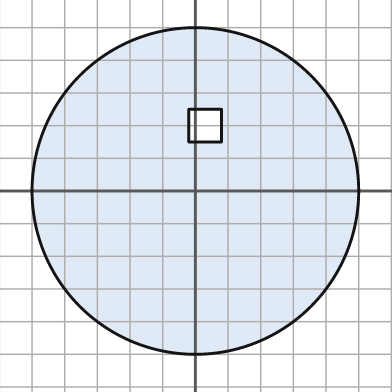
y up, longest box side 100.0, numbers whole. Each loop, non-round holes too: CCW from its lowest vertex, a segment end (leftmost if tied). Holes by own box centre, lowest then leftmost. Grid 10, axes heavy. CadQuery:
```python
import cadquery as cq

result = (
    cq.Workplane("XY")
    .moveTo(0.0, 0.0)
    .circle(50.0)
    .moveTo(-2.0, 15.0)
    .lineTo(8.0, 15.0)
    .lineTo(8.0, 25.0)
    .lineTo(-2.0, 25.0)
    .close()
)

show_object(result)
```